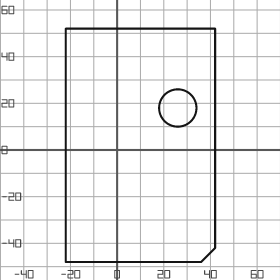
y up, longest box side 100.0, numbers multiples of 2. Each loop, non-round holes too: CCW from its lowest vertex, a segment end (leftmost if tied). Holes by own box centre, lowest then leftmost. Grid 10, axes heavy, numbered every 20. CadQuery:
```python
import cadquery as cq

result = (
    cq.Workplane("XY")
    .moveTo(-22.0, -48.0)
    .lineTo(36.0, -48.0)
    .lineTo(42.0, -42.0)
    .lineTo(42.0, 52.0)
    .lineTo(-22.0, 52.0)
    .close()
    .moveTo(26.0, 18.0)
    .circle(8.0)
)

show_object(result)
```